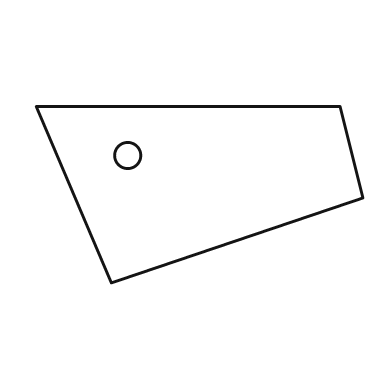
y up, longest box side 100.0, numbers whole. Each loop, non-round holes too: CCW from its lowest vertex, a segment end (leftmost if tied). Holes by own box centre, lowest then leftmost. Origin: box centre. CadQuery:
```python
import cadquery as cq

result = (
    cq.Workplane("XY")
    .moveTo(-27.0, -27.0)
    .lineTo(50.0, -1.0)
    .lineTo(43.0, 27.0)
    .lineTo(-50.0, 27.0)
    .close()
    .moveTo(-22.0, 12.0)
    .circle(4.0)
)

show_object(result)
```